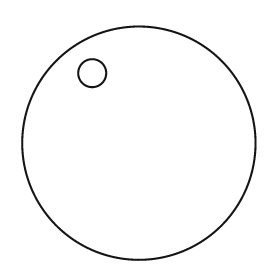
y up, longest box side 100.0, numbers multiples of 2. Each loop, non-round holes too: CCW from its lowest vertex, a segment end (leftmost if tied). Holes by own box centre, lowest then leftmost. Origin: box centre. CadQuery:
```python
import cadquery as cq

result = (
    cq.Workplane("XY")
    .moveTo(0.0, 0.0)
    .circle(50.0)
    .moveTo(-20.0, 30.0)
    .circle(6.0)
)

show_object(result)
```